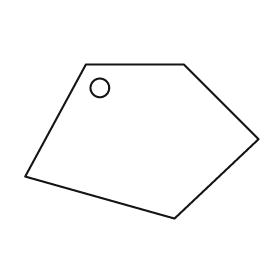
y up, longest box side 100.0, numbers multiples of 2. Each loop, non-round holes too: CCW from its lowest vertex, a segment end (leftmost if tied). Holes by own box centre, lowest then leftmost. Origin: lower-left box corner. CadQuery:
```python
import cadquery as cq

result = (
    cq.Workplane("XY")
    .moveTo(64.0, 0.0)
    .lineTo(100.0, 34.0)
    .lineTo(68.0, 66.0)
    .lineTo(26.0, 66.0)
    .lineTo(0.0, 18.0)
    .close()
    .moveTo(32.0, 56.0)
    .circle(4.0)
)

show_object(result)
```